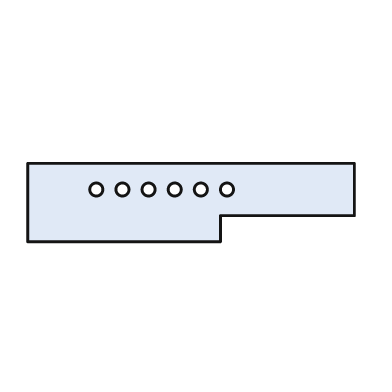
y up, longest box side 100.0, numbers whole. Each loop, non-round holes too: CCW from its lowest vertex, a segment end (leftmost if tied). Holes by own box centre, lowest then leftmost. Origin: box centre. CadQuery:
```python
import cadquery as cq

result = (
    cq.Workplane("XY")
    .moveTo(-50.0, -12.0)
    .lineTo(9.0, -12.0)
    .lineTo(9.0, -4.0)
    .lineTo(50.0, -4.0)
    .lineTo(50.0, 12.0)
    .lineTo(-50.0, 12.0)
    .close()
    .moveTo(-29.0, 4.0)
    .circle(2.0)
    .moveTo(-21.0, 4.0)
    .circle(2.0)
    .moveTo(-13.0, 4.0)
    .circle(2.0)
    .moveTo(-5.0, 4.0)
    .circle(2.0)
    .moveTo(3.0, 4.0)
    .circle(2.0)
    .moveTo(11.0, 4.0)
    .circle(2.0)
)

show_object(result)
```